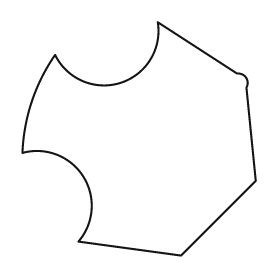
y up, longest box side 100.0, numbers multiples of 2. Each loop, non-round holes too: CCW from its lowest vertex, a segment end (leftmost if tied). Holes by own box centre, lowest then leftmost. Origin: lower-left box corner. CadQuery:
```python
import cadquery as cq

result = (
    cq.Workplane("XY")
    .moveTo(68.0, 0.0)
    .lineTo(100.0, 32.0)
    .lineTo(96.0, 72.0)
    .threePointArc((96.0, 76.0), (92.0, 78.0))
    .lineTo(58.0, 100.0)
    .threePointArc((42.0, 74.0), (14.0, 86.0))
    .threePointArc((4.0, 66.0), (0.0, 44.0))
    .threePointArc((26.0, 34.0), (24.0, 6.0))
    .close()
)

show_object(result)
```